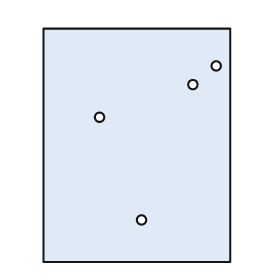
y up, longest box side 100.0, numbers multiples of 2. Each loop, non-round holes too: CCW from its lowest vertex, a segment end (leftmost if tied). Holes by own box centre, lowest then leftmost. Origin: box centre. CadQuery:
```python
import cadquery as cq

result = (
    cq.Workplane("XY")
    .moveTo(-40.0, -50.0)
    .lineTo(40.0, -50.0)
    .lineTo(40.0, 50.0)
    .lineTo(-40.0, 50.0)
    .close()
    .moveTo(2.0, -32.0)
    .circle(2.0)
    .moveTo(-16.0, 12.0)
    .circle(2.0)
    .moveTo(24.0, 26.0)
    .circle(2.0)
    .moveTo(34.0, 34.0)
    .circle(2.0)
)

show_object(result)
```